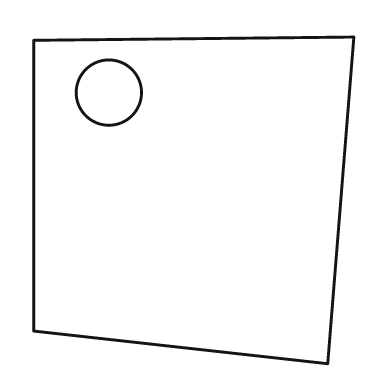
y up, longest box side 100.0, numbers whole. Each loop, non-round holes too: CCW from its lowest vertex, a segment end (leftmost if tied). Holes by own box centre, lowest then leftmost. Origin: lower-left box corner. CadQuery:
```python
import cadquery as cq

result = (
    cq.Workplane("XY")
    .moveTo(90.0, 0.0)
    .lineTo(98.0, 100.0)
    .lineTo(0.0, 99.0)
    .lineTo(0.0, 10.0)
    .close()
    .moveTo(23.0, 83.0)
    .circle(10.0)
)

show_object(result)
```